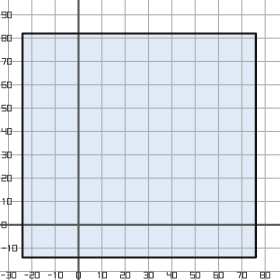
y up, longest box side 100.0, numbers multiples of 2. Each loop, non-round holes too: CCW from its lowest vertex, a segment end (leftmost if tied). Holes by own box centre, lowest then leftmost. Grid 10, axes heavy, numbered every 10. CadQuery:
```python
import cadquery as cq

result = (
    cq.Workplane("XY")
    .moveTo(-24.0, -14.0)
    .lineTo(76.0, -14.0)
    .lineTo(76.0, 82.0)
    .lineTo(-24.0, 82.0)
    .close()
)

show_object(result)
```